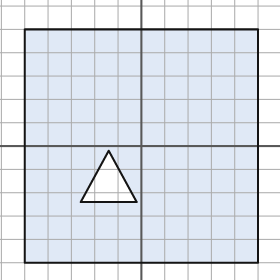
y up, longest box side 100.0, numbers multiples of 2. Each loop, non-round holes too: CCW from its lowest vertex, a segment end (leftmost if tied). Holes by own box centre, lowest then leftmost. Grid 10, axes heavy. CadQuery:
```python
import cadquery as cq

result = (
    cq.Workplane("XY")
    .moveTo(-50.0, -50.0)
    .lineTo(50.0, -50.0)
    .lineTo(50.0, 50.0)
    .lineTo(-50.0, 50.0)
    .close()
    .moveTo(-26.0, -24.0)
    .lineTo(-2.0, -24.0)
    .lineTo(-14.0, -2.0)
    .close()
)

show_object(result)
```